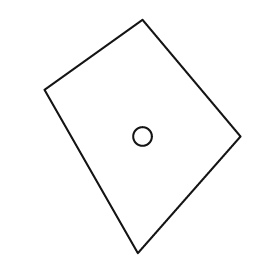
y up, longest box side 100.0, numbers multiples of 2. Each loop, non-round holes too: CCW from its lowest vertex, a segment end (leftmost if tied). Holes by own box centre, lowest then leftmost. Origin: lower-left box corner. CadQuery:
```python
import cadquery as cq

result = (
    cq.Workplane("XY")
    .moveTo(40.0, 0.0)
    .lineTo(84.0, 50.0)
    .lineTo(42.0, 100.0)
    .lineTo(0.0, 70.0)
    .close()
    .moveTo(42.0, 50.0)
    .circle(4.0)
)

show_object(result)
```